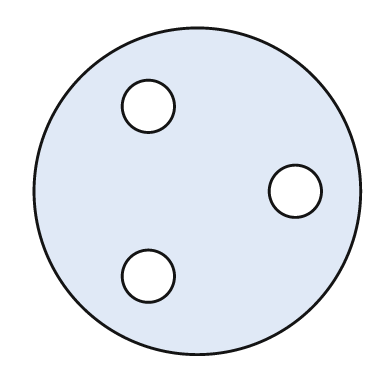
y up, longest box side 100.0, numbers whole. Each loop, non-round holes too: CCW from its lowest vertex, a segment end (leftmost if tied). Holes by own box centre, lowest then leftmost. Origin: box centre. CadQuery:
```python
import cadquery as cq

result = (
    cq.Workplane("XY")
    .moveTo(0.0, 0.0)
    .circle(50.0)
    .moveTo(-15.0, -26.0)
    .circle(8.0)
    .moveTo(30.0, 0.0)
    .circle(8.0)
    .moveTo(-15.0, 26.0)
    .circle(8.0)
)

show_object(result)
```